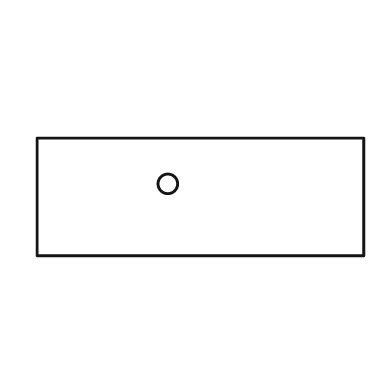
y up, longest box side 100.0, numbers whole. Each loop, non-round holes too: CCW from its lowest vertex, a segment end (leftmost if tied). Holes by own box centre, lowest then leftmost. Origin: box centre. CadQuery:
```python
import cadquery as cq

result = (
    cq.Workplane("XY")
    .moveTo(-50.0, -18.0)
    .lineTo(50.0, -18.0)
    .lineTo(50.0, 18.0)
    .lineTo(-50.0, 18.0)
    .close()
    .moveTo(-10.0, 4.0)
    .circle(3.0)
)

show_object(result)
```